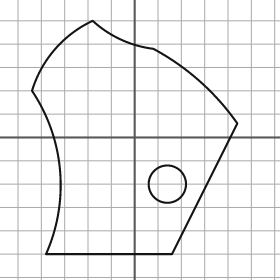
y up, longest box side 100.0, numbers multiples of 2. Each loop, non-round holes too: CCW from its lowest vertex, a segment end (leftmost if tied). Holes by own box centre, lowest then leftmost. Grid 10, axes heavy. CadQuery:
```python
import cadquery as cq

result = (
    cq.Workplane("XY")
    .moveTo(-38.0, -50.0)
    .lineTo(16.0, -50.0)
    .lineTo(44.0, 6.0)
    .threePointArc((28.0, 24.0), (8.0, 38.0))
    .threePointArc((-6.0, 42.0), (-18.0, 50.0))
    .threePointArc((-34.0, 38.0), (-44.0, 20.0))
    .threePointArc((-32.0, -14.0), (-38.0, -50.0))
    .close()
    .moveTo(14.0, -20.0)
    .circle(8.0)
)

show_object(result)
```